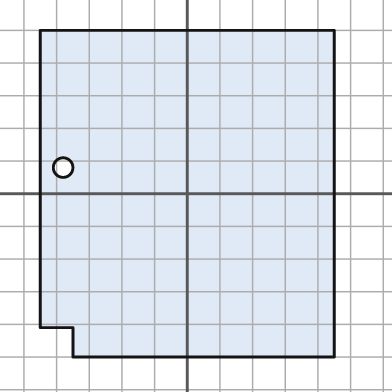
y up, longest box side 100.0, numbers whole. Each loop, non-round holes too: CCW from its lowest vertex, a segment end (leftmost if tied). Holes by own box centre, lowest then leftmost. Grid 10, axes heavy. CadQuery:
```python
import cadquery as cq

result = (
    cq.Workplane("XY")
    .moveTo(-35.0, -50.0)
    .lineTo(45.0, -50.0)
    .lineTo(45.0, 50.0)
    .lineTo(-45.0, 50.0)
    .lineTo(-45.0, -41.0)
    .lineTo(-35.0, -41.0)
    .close()
    .moveTo(-38.0, 8.0)
    .circle(3.0)
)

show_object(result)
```